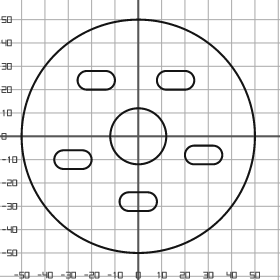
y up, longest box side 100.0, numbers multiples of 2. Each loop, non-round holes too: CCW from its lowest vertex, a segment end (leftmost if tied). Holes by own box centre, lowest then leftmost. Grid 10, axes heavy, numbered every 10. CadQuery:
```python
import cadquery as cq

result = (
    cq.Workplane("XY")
    .moveTo(0.0, 0.0)
    .circle(50.0)
    .moveTo(-4.0, -32.0)
    .lineTo(4.0, -32.0)
    .threePointArc((8.0, -28.0), (4.0, -24.0))
    .lineTo(-4.0, -24.0)
    .threePointArc((-8.0, -28.0), (-4.0, -32.0))
    .close()
    .moveTo(-32.0, -14.0)
    .lineTo(-24.0, -14.0)
    .threePointArc((-20.0, -10.0), (-24.0, -6.0))
    .lineTo(-32.0, -6.0)
    .threePointArc((-36.0, -10.0), (-32.0, -14.0))
    .close()
    .moveTo(24.0, -12.0)
    .lineTo(32.0, -12.0)
    .threePointArc((36.0, -8.0), (32.0, -4.0))
    .lineTo(24.0, -4.0)
    .threePointArc((20.0, -8.0), (24.0, -12.0))
    .close()
    .moveTo(0.0, 0.0)
    .circle(12.0)
    .moveTo(-22.0, 20.0)
    .lineTo(-14.0, 20.0)
    .threePointArc((-10.0, 24.0), (-14.0, 28.0))
    .lineTo(-22.0, 28.0)
    .threePointArc((-26.0, 24.0), (-22.0, 20.0))
    .close()
    .moveTo(12.0, 20.0)
    .lineTo(20.0, 20.0)
    .threePointArc((24.0, 24.0), (20.0, 28.0))
    .lineTo(12.0, 28.0)
    .threePointArc((8.0, 24.0), (12.0, 20.0))
    .close()
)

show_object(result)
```